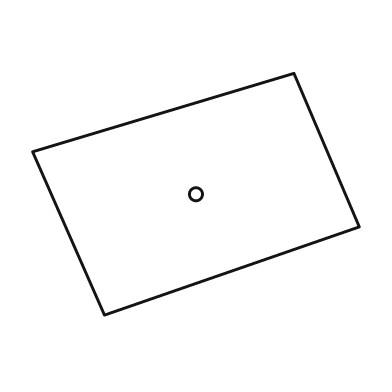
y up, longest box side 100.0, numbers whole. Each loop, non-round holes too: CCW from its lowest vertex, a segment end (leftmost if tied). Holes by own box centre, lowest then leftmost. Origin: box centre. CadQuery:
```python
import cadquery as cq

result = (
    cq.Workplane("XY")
    .moveTo(-28.0, -37.0)
    .lineTo(50.0, -10.0)
    .lineTo(30.0, 37.0)
    .lineTo(-50.0, 13.0)
    .close()
    .moveTo(0.0, 0.0)
    .circle(2.0)
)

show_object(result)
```